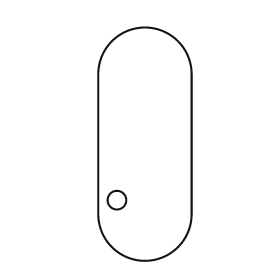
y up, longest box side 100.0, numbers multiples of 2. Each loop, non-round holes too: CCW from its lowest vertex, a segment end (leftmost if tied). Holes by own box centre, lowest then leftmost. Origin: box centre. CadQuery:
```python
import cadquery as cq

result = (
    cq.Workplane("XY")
    .moveTo(-20.0, -30.0)
    .threePointArc((0.0, -50.0), (20.0, -30.0))
    .lineTo(20.0, 30.0)
    .threePointArc((0.0, 50.0), (-20.0, 30.0))
    .close()
    .moveTo(-12.0, -24.0)
    .circle(4.0)
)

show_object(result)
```